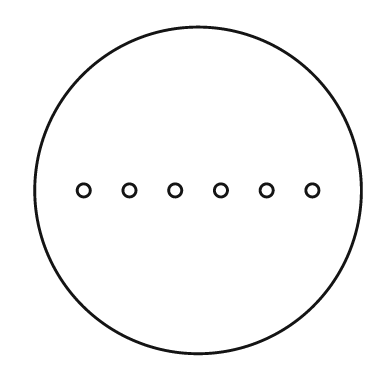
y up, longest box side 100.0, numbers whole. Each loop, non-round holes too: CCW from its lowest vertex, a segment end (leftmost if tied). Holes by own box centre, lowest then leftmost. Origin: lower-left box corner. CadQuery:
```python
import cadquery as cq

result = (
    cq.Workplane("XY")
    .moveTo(50.0, 50.0)
    .circle(50.0)
    .moveTo(15.0, 50.0)
    .circle(2.0)
    .moveTo(29.0, 50.0)
    .circle(2.0)
    .moveTo(43.0, 50.0)
    .circle(2.0)
    .moveTo(57.0, 50.0)
    .circle(2.0)
    .moveTo(71.0, 50.0)
    .circle(2.0)
    .moveTo(85.0, 50.0)
    .circle(2.0)
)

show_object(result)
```